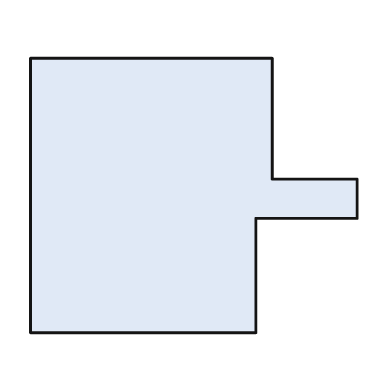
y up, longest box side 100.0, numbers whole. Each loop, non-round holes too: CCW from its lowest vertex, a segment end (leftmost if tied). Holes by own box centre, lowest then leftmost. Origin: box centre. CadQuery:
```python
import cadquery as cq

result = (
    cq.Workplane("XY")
    .moveTo(-50.0, -42.0)
    .lineTo(19.0, -42.0)
    .lineTo(19.0, -7.0)
    .lineTo(50.0, -7.0)
    .lineTo(50.0, 5.0)
    .lineTo(24.0, 5.0)
    .lineTo(24.0, 42.0)
    .lineTo(-50.0, 42.0)
    .close()
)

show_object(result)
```